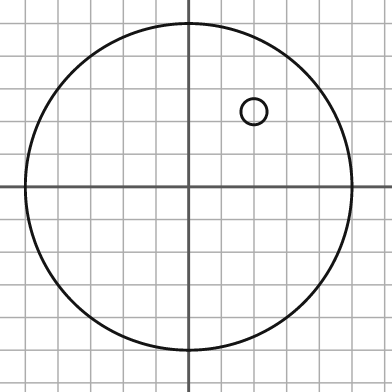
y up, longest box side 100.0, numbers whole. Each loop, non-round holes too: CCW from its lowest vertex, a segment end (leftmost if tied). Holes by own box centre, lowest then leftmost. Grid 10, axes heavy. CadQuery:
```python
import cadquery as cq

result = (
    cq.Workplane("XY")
    .moveTo(0.0, 0.0)
    .circle(50.0)
    .moveTo(20.0, 23.0)
    .circle(4.0)
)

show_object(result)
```